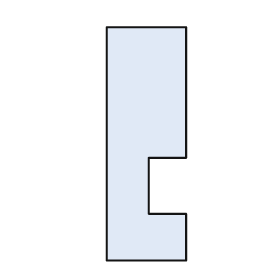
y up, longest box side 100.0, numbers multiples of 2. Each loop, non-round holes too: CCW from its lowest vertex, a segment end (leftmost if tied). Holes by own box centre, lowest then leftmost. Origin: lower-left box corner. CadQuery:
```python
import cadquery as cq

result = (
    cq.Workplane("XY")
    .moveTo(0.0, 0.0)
    .lineTo(34.0, 0.0)
    .lineTo(34.0, 20.0)
    .lineTo(18.0, 20.0)
    .lineTo(18.0, 44.0)
    .lineTo(34.0, 44.0)
    .lineTo(34.0, 100.0)
    .lineTo(0.0, 100.0)
    .close()
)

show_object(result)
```